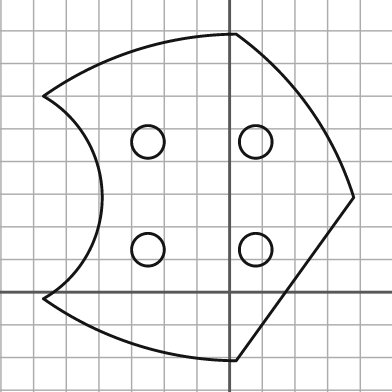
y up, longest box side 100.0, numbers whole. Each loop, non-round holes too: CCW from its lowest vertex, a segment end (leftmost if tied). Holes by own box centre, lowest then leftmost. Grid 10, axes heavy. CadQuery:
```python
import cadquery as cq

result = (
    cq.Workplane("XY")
    .moveTo(2.0, -21.0)
    .lineTo(38.0, 29.0)
    .threePointArc((24.0, 57.0), (2.0, 79.0))
    .threePointArc((-29.0, 74.0), (-57.0, 60.0))
    .threePointArc((-39.0, 29.0), (-57.0, -2.0))
    .threePointArc((-29.0, -16.0), (2.0, -21.0))
    .close()
    .moveTo(-25.0, 13.0)
    .circle(5.0)
    .moveTo(8.0, 13.0)
    .circle(5.0)
    .moveTo(-25.0, 46.0)
    .circle(5.0)
    .moveTo(8.0, 46.0)
    .circle(5.0)
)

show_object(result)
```